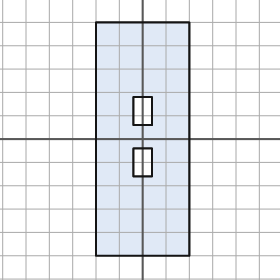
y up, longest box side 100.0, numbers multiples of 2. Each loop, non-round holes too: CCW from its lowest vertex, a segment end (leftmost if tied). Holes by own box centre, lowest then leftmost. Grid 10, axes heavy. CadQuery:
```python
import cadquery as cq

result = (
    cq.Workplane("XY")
    .moveTo(-20.0, -50.0)
    .lineTo(20.0, -50.0)
    .lineTo(20.0, 50.0)
    .lineTo(-20.0, 50.0)
    .close()
    .moveTo(-4.0, -16.0)
    .lineTo(4.0, -16.0)
    .lineTo(4.0, -4.0)
    .lineTo(-4.0, -4.0)
    .close()
    .moveTo(-4.0, 6.0)
    .lineTo(4.0, 6.0)
    .lineTo(4.0, 18.0)
    .lineTo(-4.0, 18.0)
    .close()
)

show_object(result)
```